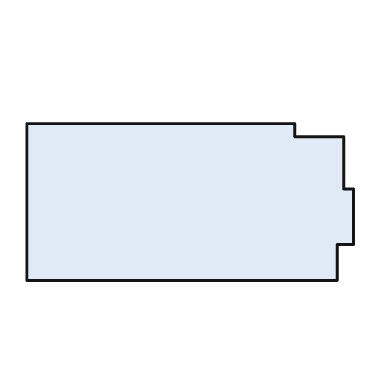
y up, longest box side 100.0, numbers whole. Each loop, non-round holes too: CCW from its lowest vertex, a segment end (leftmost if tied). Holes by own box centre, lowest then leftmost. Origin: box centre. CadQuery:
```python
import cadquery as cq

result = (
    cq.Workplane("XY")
    .moveTo(-50.0, -24.0)
    .lineTo(45.0, -24.0)
    .lineTo(45.0, -13.0)
    .lineTo(50.0, -13.0)
    .lineTo(50.0, 4.0)
    .lineTo(47.0, 4.0)
    .lineTo(47.0, 20.0)
    .lineTo(32.0, 20.0)
    .lineTo(32.0, 24.0)
    .lineTo(-50.0, 24.0)
    .close()
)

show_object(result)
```